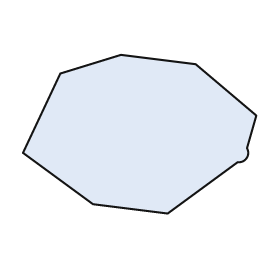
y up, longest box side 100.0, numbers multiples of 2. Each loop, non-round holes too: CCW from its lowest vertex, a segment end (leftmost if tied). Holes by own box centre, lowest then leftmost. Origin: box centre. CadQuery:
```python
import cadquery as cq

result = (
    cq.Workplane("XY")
    .moveTo(12.0, -34.0)
    .lineTo(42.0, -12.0)
    .threePointArc((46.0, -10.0), (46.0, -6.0))
    .lineTo(50.0, 8.0)
    .lineTo(24.0, 30.0)
    .lineTo(-8.0, 34.0)
    .lineTo(-34.0, 26.0)
    .lineTo(-50.0, -8.0)
    .lineTo(-20.0, -30.0)
    .close()
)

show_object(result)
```